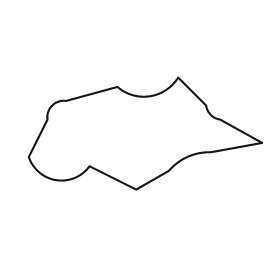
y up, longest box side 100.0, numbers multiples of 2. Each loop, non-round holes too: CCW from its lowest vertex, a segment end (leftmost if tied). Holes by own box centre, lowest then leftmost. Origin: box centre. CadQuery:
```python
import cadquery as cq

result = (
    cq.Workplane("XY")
    .moveTo(-4.0, -24.0)
    .lineTo(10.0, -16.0)
    .threePointArc((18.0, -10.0), (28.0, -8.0))
    .lineTo(50.0, -4.0)
    .lineTo(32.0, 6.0)
    .threePointArc((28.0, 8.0), (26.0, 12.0))
    .lineTo(14.0, 24.0)
    .threePointArc((2.0, 16.0), (-12.0, 20.0))
    .lineTo(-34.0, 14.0)
    .threePointArc((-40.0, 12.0), (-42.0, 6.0))
    .lineTo(-50.0, -10.0)
    .threePointArc((-38.0, -20.0), (-24.0, -14.0))
    .close()
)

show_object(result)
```